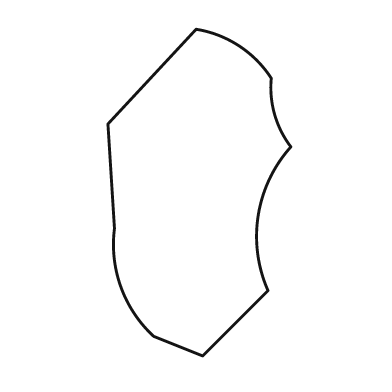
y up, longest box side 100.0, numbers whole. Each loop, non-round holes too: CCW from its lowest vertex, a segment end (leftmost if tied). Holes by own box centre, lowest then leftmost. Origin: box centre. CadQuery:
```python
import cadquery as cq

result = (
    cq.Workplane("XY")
    .moveTo(1.0, -50.0)
    .lineTo(21.0, -30.0)
    .threePointArc((18.0, -7.0), (28.0, 14.0))
    .threePointArc((23.0, 24.0), (22.0, 35.0))
    .threePointArc((12.0, 45.0), (-1.0, 50.0))
    .lineTo(-28.0, 21.0)
    .lineTo(-26.0, -11.0)
    .threePointArc((-24.0, -29.0), (-14.0, -44.0))
    .close()
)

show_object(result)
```